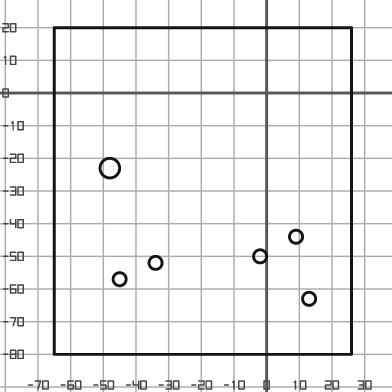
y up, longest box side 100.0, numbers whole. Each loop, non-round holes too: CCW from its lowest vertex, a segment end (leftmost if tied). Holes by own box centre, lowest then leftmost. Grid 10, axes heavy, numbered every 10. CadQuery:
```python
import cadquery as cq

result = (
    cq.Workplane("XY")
    .moveTo(-65.0, -80.0)
    .lineTo(26.0, -80.0)
    .lineTo(26.0, 20.0)
    .lineTo(-65.0, 20.0)
    .close()
    .moveTo(13.0, -63.0)
    .circle(2.0)
    .moveTo(-45.0, -57.0)
    .circle(2.0)
    .moveTo(-34.0, -52.0)
    .circle(2.0)
    .moveTo(-2.0, -50.0)
    .circle(2.0)
    .moveTo(9.0, -44.0)
    .circle(2.0)
    .moveTo(-48.0, -23.0)
    .circle(3.0)
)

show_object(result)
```